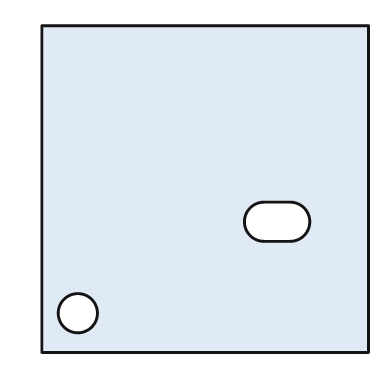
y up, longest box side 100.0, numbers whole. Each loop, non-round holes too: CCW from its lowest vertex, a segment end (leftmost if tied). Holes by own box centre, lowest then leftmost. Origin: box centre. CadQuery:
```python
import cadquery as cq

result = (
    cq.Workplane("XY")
    .moveTo(-50.0, -50.0)
    .lineTo(50.0, -50.0)
    .lineTo(50.0, 50.0)
    .lineTo(-50.0, 50.0)
    .close()
    .moveTo(-39.0, -38.0)
    .circle(6.0)
    .moveTo(18.0, -16.0)
    .lineTo(26.0, -16.0)
    .threePointArc((32.0, -10.0), (26.0, -4.0))
    .lineTo(18.0, -4.0)
    .threePointArc((12.0, -10.0), (18.0, -16.0))
    .close()
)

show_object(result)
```